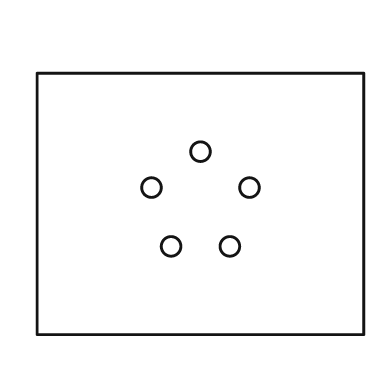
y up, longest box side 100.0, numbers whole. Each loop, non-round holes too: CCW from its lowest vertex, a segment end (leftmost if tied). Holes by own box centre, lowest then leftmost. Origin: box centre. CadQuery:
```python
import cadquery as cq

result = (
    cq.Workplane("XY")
    .moveTo(-50.0, -40.0)
    .lineTo(50.0, -40.0)
    .lineTo(50.0, 40.0)
    .lineTo(-50.0, 40.0)
    .close()
    .moveTo(-9.0, -13.0)
    .circle(3.0)
    .moveTo(9.0, -13.0)
    .circle(3.0)
    .moveTo(-15.0, 5.0)
    .circle(3.0)
    .moveTo(15.0, 5.0)
    .circle(3.0)
    .moveTo(0.0, 16.0)
    .circle(3.0)
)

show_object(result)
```